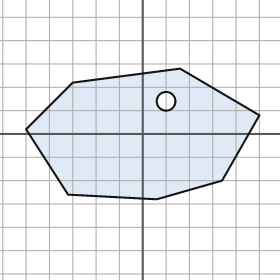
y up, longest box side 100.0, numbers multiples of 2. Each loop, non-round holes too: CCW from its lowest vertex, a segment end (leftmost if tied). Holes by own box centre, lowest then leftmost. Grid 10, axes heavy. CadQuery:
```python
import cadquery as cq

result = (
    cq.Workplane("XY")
    .moveTo(6.0, -28.0)
    .lineTo(34.0, -20.0)
    .lineTo(50.0, 8.0)
    .lineTo(16.0, 28.0)
    .lineTo(-30.0, 22.0)
    .lineTo(-50.0, 2.0)
    .lineTo(-32.0, -26.0)
    .close()
    .moveTo(10.0, 14.0)
    .circle(4.0)
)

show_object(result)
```